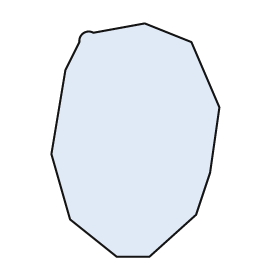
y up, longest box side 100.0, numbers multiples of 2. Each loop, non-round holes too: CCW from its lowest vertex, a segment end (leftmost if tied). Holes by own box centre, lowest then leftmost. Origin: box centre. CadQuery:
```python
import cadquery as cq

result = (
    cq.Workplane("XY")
    .moveTo(-8.0, -50.0)
    .lineTo(6.0, -50.0)
    .lineTo(26.0, -32.0)
    .lineTo(32.0, -14.0)
    .lineTo(36.0, 14.0)
    .lineTo(24.0, 42.0)
    .lineTo(4.0, 50.0)
    .lineTo(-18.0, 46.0)
    .threePointArc((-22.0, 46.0), (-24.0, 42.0))
    .lineTo(-30.0, 30.0)
    .lineTo(-36.0, -6.0)
    .lineTo(-28.0, -34.0)
    .close()
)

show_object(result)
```